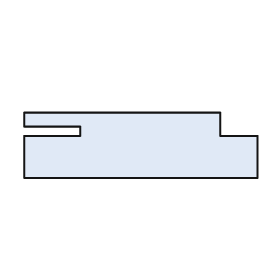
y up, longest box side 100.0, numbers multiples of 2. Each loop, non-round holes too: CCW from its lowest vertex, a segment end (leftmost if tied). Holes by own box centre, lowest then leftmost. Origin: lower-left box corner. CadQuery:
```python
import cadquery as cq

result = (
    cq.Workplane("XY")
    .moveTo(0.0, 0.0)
    .lineTo(100.0, 0.0)
    .lineTo(100.0, 18.0)
    .lineTo(84.0, 18.0)
    .lineTo(84.0, 28.0)
    .lineTo(0.0, 28.0)
    .lineTo(0.0, 22.0)
    .lineTo(24.0, 22.0)
    .lineTo(24.0, 18.0)
    .lineTo(0.0, 18.0)
    .close()
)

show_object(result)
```